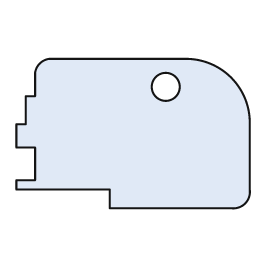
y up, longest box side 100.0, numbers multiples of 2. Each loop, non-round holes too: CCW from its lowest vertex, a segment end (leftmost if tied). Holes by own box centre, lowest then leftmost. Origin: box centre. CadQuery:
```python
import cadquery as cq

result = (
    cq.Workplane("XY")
    .moveTo(-10.0, -32.0)
    .lineTo(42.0, -32.0)
    .threePointArc((48.0, -30.0), (50.0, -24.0))
    .lineTo(50.0, 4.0)
    .threePointArc((42.0, 24.0), (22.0, 32.0))
    .lineTo(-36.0, 32.0)
    .threePointArc((-40.0, 30.0), (-42.0, 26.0))
    .lineTo(-42.0, 16.0)
    .lineTo(-46.0, 16.0)
    .lineTo(-46.0, 4.0)
    .lineTo(-50.0, 4.0)
    .lineTo(-50.0, -6.0)
    .lineTo(-42.0, -6.0)
    .lineTo(-42.0, -20.0)
    .lineTo(-50.0, -20.0)
    .lineTo(-50.0, -24.0)
    .lineTo(-10.0, -24.0)
    .close()
    .moveTo(14.0, 20.0)
    .circle(6.0)
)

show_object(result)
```